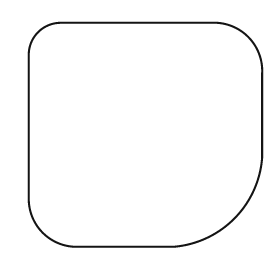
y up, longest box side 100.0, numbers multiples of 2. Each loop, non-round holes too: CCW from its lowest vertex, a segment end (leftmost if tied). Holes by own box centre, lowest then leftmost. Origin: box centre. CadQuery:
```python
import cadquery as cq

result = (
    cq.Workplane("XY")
    .moveTo(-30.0, -48.0)
    .lineTo(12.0, -48.0)
    .threePointArc((38.0, -36.0), (50.0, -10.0))
    .lineTo(50.0, 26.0)
    .threePointArc((44.0, 42.0), (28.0, 48.0))
    .lineTo(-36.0, 48.0)
    .threePointArc((-46.0, 44.0), (-50.0, 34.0))
    .lineTo(-50.0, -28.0)
    .threePointArc((-44.0, -42.0), (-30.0, -48.0))
    .close()
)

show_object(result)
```